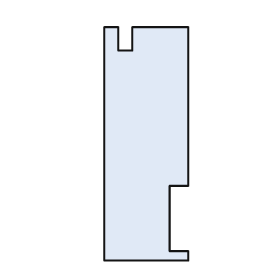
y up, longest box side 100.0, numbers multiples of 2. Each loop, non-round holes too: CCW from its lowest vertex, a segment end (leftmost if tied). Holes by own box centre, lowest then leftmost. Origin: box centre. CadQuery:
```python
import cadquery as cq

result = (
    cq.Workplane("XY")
    .moveTo(-18.0, -50.0)
    .lineTo(18.0, -50.0)
    .lineTo(18.0, -46.0)
    .lineTo(10.0, -46.0)
    .lineTo(10.0, -18.0)
    .lineTo(18.0, -18.0)
    .lineTo(18.0, 50.0)
    .lineTo(-6.0, 50.0)
    .lineTo(-6.0, 40.0)
    .lineTo(-12.0, 40.0)
    .lineTo(-12.0, 50.0)
    .lineTo(-18.0, 50.0)
    .close()
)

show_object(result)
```